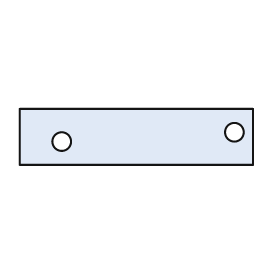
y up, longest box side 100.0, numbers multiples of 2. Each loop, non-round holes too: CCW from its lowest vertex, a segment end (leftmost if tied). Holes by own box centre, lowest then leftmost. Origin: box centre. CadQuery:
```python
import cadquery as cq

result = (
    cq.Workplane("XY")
    .moveTo(-50.0, -12.0)
    .lineTo(50.0, -12.0)
    .lineTo(50.0, 12.0)
    .lineTo(-50.0, 12.0)
    .close()
    .moveTo(-32.0, -2.0)
    .circle(4.0)
    .moveTo(42.0, 2.0)
    .circle(4.0)
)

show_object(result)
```